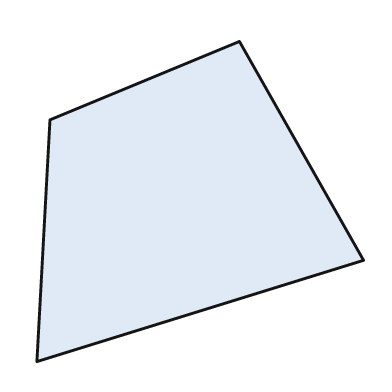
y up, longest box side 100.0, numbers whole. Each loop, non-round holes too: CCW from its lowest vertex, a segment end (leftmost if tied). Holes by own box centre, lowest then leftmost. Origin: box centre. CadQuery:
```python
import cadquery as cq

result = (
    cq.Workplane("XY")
    .moveTo(-50.0, -49.0)
    .lineTo(50.0, -18.0)
    .lineTo(12.0, 49.0)
    .lineTo(-46.0, 25.0)
    .close()
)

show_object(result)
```